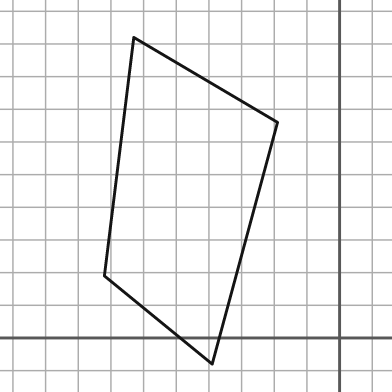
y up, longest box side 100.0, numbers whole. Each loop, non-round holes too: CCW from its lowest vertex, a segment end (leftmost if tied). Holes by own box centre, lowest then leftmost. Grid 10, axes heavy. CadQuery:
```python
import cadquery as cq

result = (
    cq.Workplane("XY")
    .moveTo(-39.0, -8.0)
    .lineTo(-19.0, 66.0)
    .lineTo(-63.0, 92.0)
    .lineTo(-72.0, 19.0)
    .close()
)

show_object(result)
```